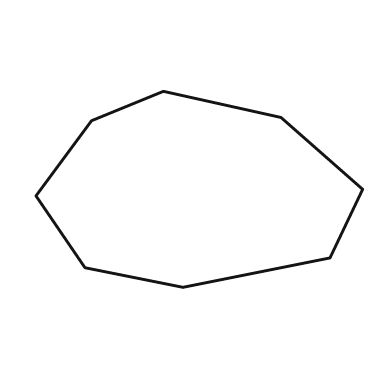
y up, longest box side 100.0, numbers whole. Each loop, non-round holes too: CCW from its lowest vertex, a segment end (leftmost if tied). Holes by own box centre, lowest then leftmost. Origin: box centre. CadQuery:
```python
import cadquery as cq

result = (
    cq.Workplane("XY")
    .moveTo(-5.0, -30.0)
    .lineTo(40.0, -21.0)
    .lineTo(50.0, 0.0)
    .lineTo(25.0, 22.0)
    .lineTo(-11.0, 30.0)
    .lineTo(-33.0, 21.0)
    .lineTo(-50.0, -2.0)
    .lineTo(-35.0, -24.0)
    .close()
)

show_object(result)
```